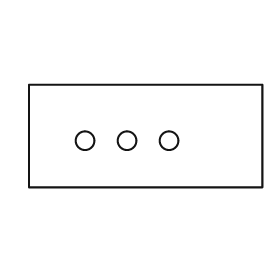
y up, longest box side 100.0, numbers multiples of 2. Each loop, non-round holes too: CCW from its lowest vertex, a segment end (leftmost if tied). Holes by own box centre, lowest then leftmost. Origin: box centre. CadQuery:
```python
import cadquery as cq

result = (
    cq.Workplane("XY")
    .moveTo(-50.0, -22.0)
    .lineTo(50.0, -22.0)
    .lineTo(50.0, 22.0)
    .lineTo(-50.0, 22.0)
    .close()
    .moveTo(-26.0, -2.0)
    .circle(4.0)
    .moveTo(-8.0, -2.0)
    .circle(4.0)
    .moveTo(10.0, -2.0)
    .circle(4.0)
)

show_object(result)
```